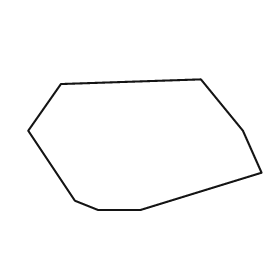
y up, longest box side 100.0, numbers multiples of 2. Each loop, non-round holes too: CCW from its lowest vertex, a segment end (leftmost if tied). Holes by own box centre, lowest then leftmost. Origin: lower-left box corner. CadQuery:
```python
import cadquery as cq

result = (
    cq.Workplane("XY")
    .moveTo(30.0, 0.0)
    .lineTo(48.0, 0.0)
    .lineTo(100.0, 16.0)
    .lineTo(92.0, 34.0)
    .lineTo(74.0, 56.0)
    .lineTo(14.0, 54.0)
    .lineTo(0.0, 34.0)
    .lineTo(20.0, 4.0)
    .close()
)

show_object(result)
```